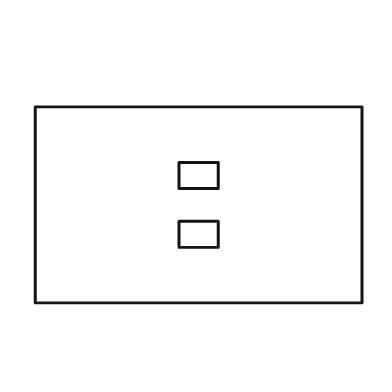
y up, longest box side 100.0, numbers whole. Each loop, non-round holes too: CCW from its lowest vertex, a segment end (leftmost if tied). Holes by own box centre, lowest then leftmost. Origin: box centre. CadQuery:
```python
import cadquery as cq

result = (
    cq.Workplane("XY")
    .moveTo(-50.0, -30.0)
    .lineTo(50.0, -30.0)
    .lineTo(50.0, 30.0)
    .lineTo(-50.0, 30.0)
    .close()
    .moveTo(-6.0, -13.0)
    .lineTo(6.0, -13.0)
    .lineTo(6.0, -5.0)
    .lineTo(-6.0, -5.0)
    .close()
    .moveTo(-6.0, 5.0)
    .lineTo(6.0, 5.0)
    .lineTo(6.0, 13.0)
    .lineTo(-6.0, 13.0)
    .close()
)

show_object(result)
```